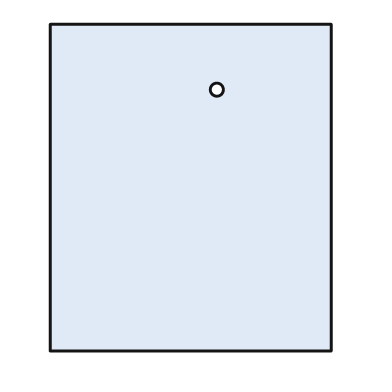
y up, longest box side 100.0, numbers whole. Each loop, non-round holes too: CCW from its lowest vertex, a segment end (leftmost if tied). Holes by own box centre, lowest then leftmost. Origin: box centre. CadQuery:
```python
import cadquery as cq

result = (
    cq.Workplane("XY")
    .moveTo(-43.0, -50.0)
    .lineTo(43.0, -50.0)
    .lineTo(43.0, 50.0)
    .lineTo(-43.0, 50.0)
    .close()
    .moveTo(8.0, 30.0)
    .circle(2.0)
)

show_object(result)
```